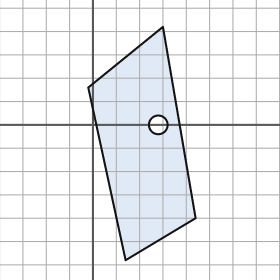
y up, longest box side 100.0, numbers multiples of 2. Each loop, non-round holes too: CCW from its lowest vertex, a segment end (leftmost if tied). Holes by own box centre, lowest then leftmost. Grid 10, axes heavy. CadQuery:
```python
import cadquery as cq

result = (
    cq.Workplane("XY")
    .moveTo(14.0, -58.0)
    .lineTo(44.0, -40.0)
    .lineTo(30.0, 42.0)
    .lineTo(-2.0, 16.0)
    .close()
    .moveTo(28.0, 0.0)
    .circle(4.0)
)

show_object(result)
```